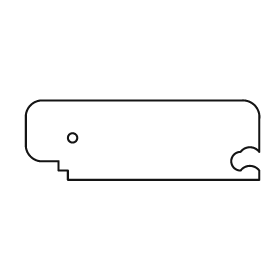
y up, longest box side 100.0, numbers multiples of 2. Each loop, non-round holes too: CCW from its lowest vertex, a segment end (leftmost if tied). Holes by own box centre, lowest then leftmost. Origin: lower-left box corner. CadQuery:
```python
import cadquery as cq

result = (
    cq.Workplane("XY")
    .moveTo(18.0, 0.0)
    .lineTo(100.0, 0.0)
    .lineTo(100.0, 4.0)
    .threePointArc((96.0, 6.0), (92.0, 4.0))
    .threePointArc((88.0, 8.0), (92.0, 12.0))
    .threePointArc((96.0, 14.0), (100.0, 12.0))
    .lineTo(100.0, 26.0)
    .threePointArc((98.0, 32.0), (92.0, 34.0))
    .lineTo(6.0, 34.0)
    .threePointArc((2.0, 32.0), (0.0, 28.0))
    .lineTo(0.0, 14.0)
    .threePointArc((2.0, 10.0), (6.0, 8.0))
    .lineTo(14.0, 8.0)
    .lineTo(14.0, 4.0)
    .lineTo(18.0, 4.0)
    .close()
    .moveTo(20.0, 18.0)
    .circle(2.0)
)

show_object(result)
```